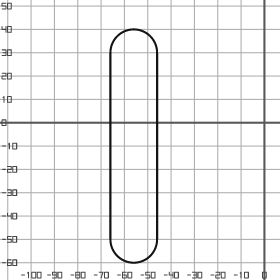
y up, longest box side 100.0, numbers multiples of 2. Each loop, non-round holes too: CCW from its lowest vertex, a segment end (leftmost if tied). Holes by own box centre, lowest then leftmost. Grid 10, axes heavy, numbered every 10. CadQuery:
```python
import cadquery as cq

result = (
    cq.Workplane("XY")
    .moveTo(-66.0, -50.0)
    .threePointArc((-56.0, -60.0), (-46.0, -50.0))
    .lineTo(-46.0, 30.0)
    .threePointArc((-56.0, 40.0), (-66.0, 30.0))
    .close()
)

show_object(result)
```